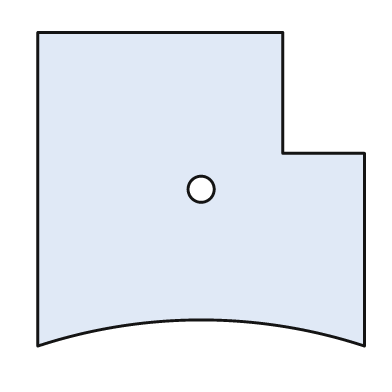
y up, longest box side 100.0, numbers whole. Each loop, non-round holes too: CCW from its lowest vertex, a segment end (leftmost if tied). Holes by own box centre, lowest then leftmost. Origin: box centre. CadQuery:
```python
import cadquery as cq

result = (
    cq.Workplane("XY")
    .moveTo(-50.0, -48.0)
    .threePointArc((0.0, -40.0), (50.0, -48.0))
    .lineTo(50.0, 11.0)
    .lineTo(25.0, 11.0)
    .lineTo(25.0, 48.0)
    .lineTo(-50.0, 48.0)
    .close()
    .moveTo(0.0, 0.0)
    .circle(4.0)
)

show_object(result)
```